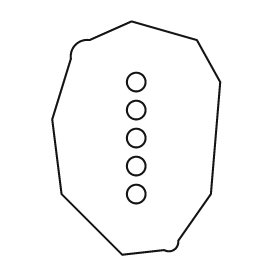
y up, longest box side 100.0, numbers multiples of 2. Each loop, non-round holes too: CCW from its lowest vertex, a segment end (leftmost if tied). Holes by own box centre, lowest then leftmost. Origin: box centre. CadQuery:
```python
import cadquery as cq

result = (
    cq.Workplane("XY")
    .moveTo(-6.0, -50.0)
    .lineTo(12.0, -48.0)
    .threePointArc((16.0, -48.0), (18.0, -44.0))
    .lineTo(32.0, -24.0)
    .lineTo(36.0, 24.0)
    .lineTo(26.0, 42.0)
    .lineTo(-2.0, 50.0)
    .lineTo(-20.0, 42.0)
    .threePointArc((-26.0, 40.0), (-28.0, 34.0))
    .lineTo(-36.0, 8.0)
    .lineTo(-32.0, -24.0)
    .close()
    .moveTo(0.0, -24.0)
    .circle(4.0)
    .moveTo(0.0, -12.0)
    .circle(4.0)
    .moveTo(0.0, 0.0)
    .circle(4.0)
    .moveTo(0.0, 12.0)
    .circle(4.0)
    .moveTo(0.0, 24.0)
    .circle(4.0)
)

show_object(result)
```